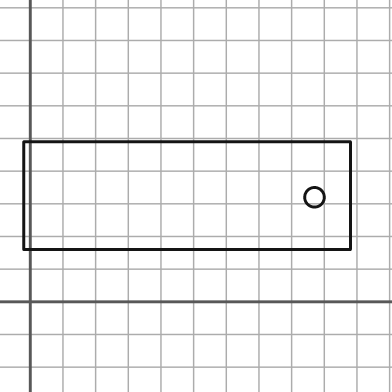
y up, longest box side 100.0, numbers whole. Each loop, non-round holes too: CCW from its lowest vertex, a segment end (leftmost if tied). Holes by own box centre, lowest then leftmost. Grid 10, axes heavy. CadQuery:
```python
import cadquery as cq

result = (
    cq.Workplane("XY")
    .moveTo(-2.0, 16.0)
    .lineTo(98.0, 16.0)
    .lineTo(98.0, 49.0)
    .lineTo(-2.0, 49.0)
    .close()
    .moveTo(87.0, 32.0)
    .circle(3.0)
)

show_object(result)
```